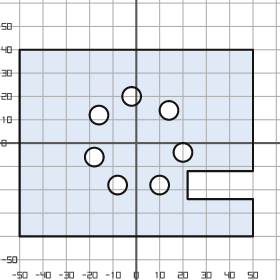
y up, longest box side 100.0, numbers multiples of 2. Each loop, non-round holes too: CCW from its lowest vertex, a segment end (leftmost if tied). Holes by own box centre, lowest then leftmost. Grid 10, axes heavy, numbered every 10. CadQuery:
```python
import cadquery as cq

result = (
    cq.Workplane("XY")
    .moveTo(-50.0, -40.0)
    .lineTo(50.0, -40.0)
    .lineTo(50.0, -24.0)
    .lineTo(22.0, -24.0)
    .lineTo(22.0, -12.0)
    .lineTo(50.0, -12.0)
    .lineTo(50.0, 40.0)
    .lineTo(-50.0, 40.0)
    .close()
    .moveTo(-8.0, -18.0)
    .circle(4.0)
    .moveTo(10.0, -18.0)
    .circle(4.0)
    .moveTo(-18.0, -6.0)
    .circle(4.0)
    .moveTo(20.0, -4.0)
    .circle(4.0)
    .moveTo(-16.0, 12.0)
    .circle(4.0)
    .moveTo(14.0, 14.0)
    .circle(4.0)
    .moveTo(-2.0, 20.0)
    .circle(4.0)
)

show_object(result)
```